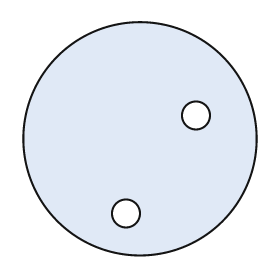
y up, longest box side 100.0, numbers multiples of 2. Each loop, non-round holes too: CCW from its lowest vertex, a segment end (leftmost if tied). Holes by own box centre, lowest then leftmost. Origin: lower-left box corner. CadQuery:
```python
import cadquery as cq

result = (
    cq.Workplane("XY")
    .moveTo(50.0, 50.0)
    .circle(50.0)
    .moveTo(44.0, 18.0)
    .circle(6.0)
    .moveTo(74.0, 60.0)
    .circle(6.0)
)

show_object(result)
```